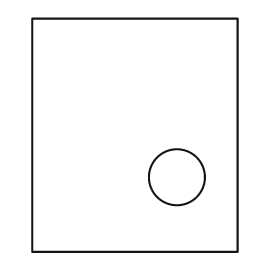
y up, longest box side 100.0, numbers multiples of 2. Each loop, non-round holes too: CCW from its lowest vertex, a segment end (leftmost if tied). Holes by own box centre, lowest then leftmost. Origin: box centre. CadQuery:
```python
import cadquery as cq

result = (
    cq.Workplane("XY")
    .moveTo(-44.0, -50.0)
    .lineTo(44.0, -50.0)
    .lineTo(44.0, 50.0)
    .lineTo(-44.0, 50.0)
    .close()
    .moveTo(18.0, -18.0)
    .circle(12.0)
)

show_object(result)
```